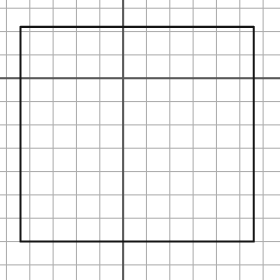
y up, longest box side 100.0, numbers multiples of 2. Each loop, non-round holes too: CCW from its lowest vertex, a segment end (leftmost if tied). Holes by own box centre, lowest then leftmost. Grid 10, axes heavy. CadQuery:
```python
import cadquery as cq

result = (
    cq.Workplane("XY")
    .moveTo(-44.0, -70.0)
    .lineTo(56.0, -70.0)
    .lineTo(56.0, 22.0)
    .lineTo(-44.0, 22.0)
    .close()
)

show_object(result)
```